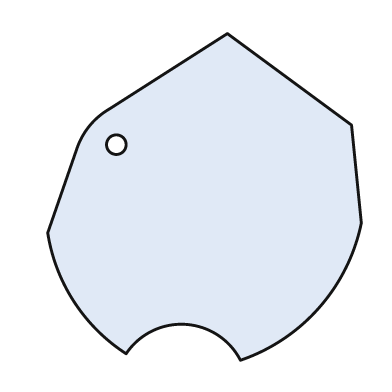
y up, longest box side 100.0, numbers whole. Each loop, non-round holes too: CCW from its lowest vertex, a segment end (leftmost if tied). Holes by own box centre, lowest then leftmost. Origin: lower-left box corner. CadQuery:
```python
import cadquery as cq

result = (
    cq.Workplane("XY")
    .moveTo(59.0, 0.0)
    .threePointArc((83.0, 16.0), (96.0, 42.0))
    .lineTo(93.0, 72.0)
    .lineTo(55.0, 100.0)
    .lineTo(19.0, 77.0)
    .threePointArc((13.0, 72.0), (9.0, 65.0))
    .lineTo(0.0, 39.0)
    .threePointArc((8.0, 18.0), (24.0, 2.0))
    .threePointArc((42.0, 11.0), (59.0, 0.0))
    .close()
    .moveTo(21.0, 66.0)
    .circle(3.0)
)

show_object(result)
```